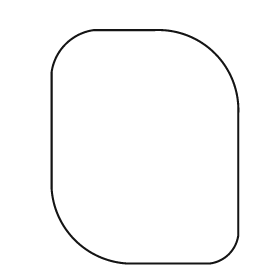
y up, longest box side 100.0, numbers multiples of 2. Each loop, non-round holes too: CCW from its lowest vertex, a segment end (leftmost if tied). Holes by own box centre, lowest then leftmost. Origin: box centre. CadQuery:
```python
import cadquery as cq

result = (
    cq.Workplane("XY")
    .moveTo(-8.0, -50.0)
    .lineTo(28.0, -50.0)
    .threePointArc((36.0, -46.0), (40.0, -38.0))
    .lineTo(40.0, 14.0)
    .threePointArc((30.0, 40.0), (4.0, 50.0))
    .lineTo(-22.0, 50.0)
    .threePointArc((-34.0, 44.0), (-40.0, 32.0))
    .lineTo(-40.0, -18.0)
    .threePointArc((-30.0, -40.0), (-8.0, -50.0))
    .close()
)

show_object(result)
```